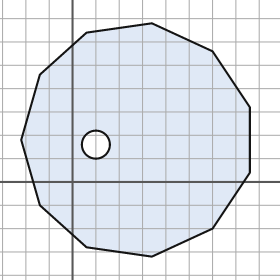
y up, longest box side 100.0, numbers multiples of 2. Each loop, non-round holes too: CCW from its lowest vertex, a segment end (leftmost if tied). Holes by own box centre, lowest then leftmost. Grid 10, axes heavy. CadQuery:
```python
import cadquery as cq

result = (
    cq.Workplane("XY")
    .moveTo(34.0, -32.0)
    .lineTo(60.0, -20.0)
    .lineTo(76.0, 4.0)
    .lineTo(76.0, 32.0)
    .lineTo(60.0, 56.0)
    .lineTo(34.0, 68.0)
    .lineTo(6.0, 64.0)
    .lineTo(-14.0, 46.0)
    .lineTo(-22.0, 18.0)
    .lineTo(-14.0, -10.0)
    .lineTo(6.0, -28.0)
    .close()
    .moveTo(10.0, 16.0)
    .circle(6.0)
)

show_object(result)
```